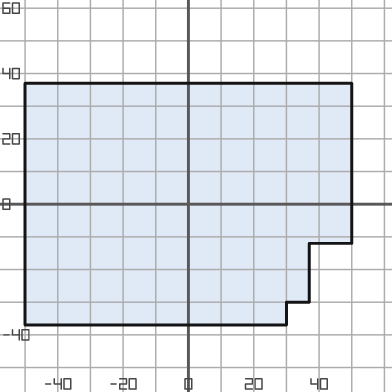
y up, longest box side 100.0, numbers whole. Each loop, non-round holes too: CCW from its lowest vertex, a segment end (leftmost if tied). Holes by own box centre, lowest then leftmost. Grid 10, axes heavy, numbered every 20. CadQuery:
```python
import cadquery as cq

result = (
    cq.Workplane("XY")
    .moveTo(-50.0, -37.0)
    .lineTo(30.0, -37.0)
    .lineTo(30.0, -30.0)
    .lineTo(37.0, -30.0)
    .lineTo(37.0, -12.0)
    .lineTo(50.0, -12.0)
    .lineTo(50.0, 37.0)
    .lineTo(-50.0, 37.0)
    .close()
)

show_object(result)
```